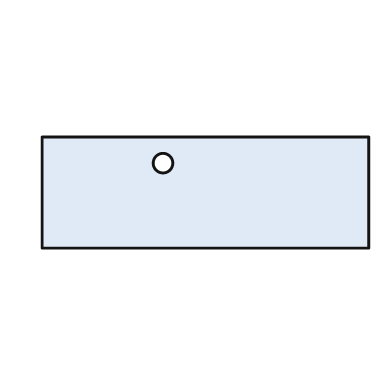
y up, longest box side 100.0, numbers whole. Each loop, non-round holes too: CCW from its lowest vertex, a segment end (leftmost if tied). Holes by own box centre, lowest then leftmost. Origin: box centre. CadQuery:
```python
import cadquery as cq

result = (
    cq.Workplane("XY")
    .moveTo(-50.0, -17.0)
    .lineTo(50.0, -17.0)
    .lineTo(50.0, 17.0)
    .lineTo(-50.0, 17.0)
    .close()
    .moveTo(-13.0, 9.0)
    .circle(3.0)
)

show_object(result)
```